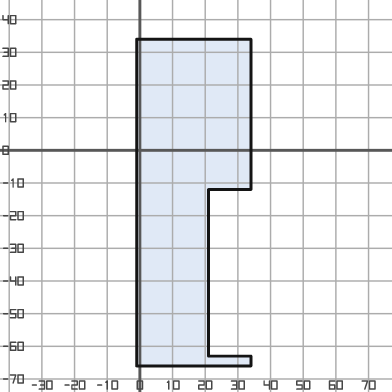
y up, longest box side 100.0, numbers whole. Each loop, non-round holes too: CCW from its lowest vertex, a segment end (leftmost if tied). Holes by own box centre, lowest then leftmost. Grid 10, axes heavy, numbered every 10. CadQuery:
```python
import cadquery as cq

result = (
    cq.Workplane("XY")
    .moveTo(-1.0, -66.0)
    .lineTo(34.0, -66.0)
    .lineTo(34.0, -63.0)
    .lineTo(21.0, -63.0)
    .lineTo(21.0, -12.0)
    .lineTo(34.0, -12.0)
    .lineTo(34.0, 34.0)
    .lineTo(-1.0, 34.0)
    .close()
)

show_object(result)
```